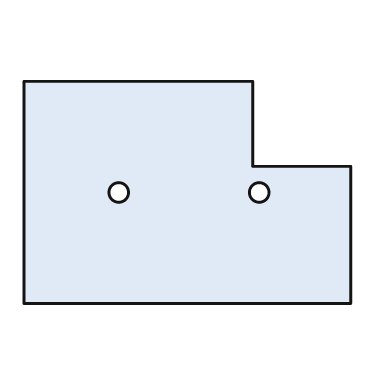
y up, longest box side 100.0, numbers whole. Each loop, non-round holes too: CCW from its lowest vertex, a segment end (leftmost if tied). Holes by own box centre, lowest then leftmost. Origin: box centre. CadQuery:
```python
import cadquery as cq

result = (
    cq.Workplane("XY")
    .moveTo(-50.0, -34.0)
    .lineTo(50.0, -34.0)
    .lineTo(50.0, 8.0)
    .lineTo(20.0, 8.0)
    .lineTo(20.0, 34.0)
    .lineTo(-50.0, 34.0)
    .close()
    .moveTo(-21.0, 0.0)
    .circle(3.0)
    .moveTo(22.0, 0.0)
    .circle(3.0)
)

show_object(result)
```